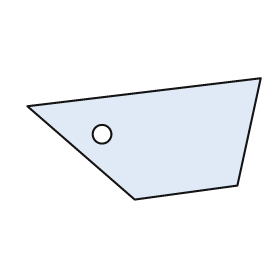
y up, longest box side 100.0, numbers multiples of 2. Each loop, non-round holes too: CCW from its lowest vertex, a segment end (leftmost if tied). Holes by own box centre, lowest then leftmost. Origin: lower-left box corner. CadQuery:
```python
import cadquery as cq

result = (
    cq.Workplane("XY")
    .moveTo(46.0, 0.0)
    .lineTo(90.0, 6.0)
    .lineTo(100.0, 52.0)
    .lineTo(0.0, 40.0)
    .close()
    .moveTo(32.0, 28.0)
    .circle(4.0)
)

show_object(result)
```